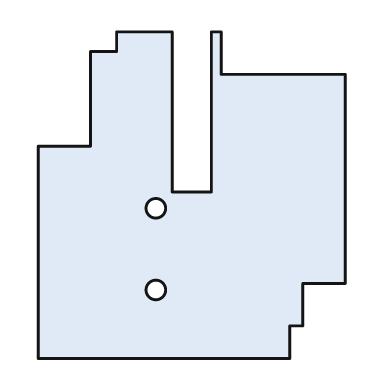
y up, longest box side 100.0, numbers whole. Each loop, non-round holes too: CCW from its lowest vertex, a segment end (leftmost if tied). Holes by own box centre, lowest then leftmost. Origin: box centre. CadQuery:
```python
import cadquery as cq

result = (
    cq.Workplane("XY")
    .moveTo(-47.0, -50.0)
    .lineTo(30.0, -50.0)
    .lineTo(30.0, -40.0)
    .lineTo(34.0, -40.0)
    .lineTo(34.0, -27.0)
    .lineTo(47.0, -27.0)
    .lineTo(47.0, 37.0)
    .lineTo(9.0, 37.0)
    .lineTo(9.0, 50.0)
    .lineTo(6.0, 50.0)
    .lineTo(6.0, 1.0)
    .lineTo(-6.0, 1.0)
    .lineTo(-6.0, 50.0)
    .lineTo(-23.0, 50.0)
    .lineTo(-23.0, 44.0)
    .lineTo(-31.0, 44.0)
    .lineTo(-31.0, 15.0)
    .lineTo(-47.0, 15.0)
    .close()
    .moveTo(-11.0, -29.0)
    .circle(3.0)
    .moveTo(-11.0, -4.0)
    .circle(3.0)
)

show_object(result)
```